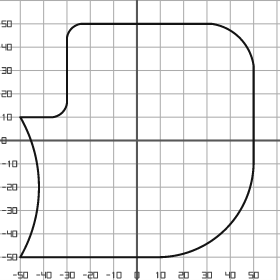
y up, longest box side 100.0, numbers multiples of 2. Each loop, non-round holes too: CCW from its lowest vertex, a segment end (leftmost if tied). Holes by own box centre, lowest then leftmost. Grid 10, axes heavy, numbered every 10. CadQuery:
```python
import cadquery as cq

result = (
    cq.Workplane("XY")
    .moveTo(-50.0, -50.0)
    .lineTo(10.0, -50.0)
    .threePointArc((38.0, -38.0), (50.0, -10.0))
    .lineTo(50.0, 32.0)
    .threePointArc((44.0, 44.0), (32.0, 50.0))
    .lineTo(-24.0, 50.0)
    .threePointArc((-28.0, 48.0), (-30.0, 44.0))
    .lineTo(-30.0, 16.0)
    .threePointArc((-32.0, 12.0), (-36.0, 10.0))
    .lineTo(-50.0, 10.0)
    .threePointArc((-42.0, -20.0), (-50.0, -50.0))
    .close()
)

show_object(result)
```